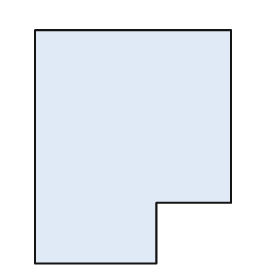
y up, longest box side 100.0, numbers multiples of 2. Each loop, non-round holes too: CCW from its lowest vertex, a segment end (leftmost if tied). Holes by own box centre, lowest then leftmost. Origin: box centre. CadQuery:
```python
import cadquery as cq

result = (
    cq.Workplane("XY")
    .moveTo(-42.0, -50.0)
    .lineTo(10.0, -50.0)
    .lineTo(10.0, -24.0)
    .lineTo(42.0, -24.0)
    .lineTo(42.0, 50.0)
    .lineTo(-42.0, 50.0)
    .close()
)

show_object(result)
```